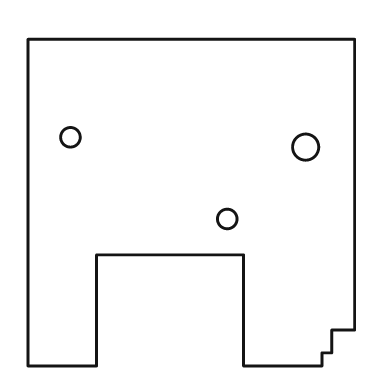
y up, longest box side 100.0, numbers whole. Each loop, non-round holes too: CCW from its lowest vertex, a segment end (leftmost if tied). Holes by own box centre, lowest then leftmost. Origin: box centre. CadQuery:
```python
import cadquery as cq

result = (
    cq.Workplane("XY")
    .moveTo(-50.0, -50.0)
    .lineTo(-29.0, -50.0)
    .lineTo(-29.0, -16.0)
    .lineTo(16.0, -16.0)
    .lineTo(16.0, -50.0)
    .lineTo(40.0, -50.0)
    .lineTo(40.0, -46.0)
    .lineTo(43.0, -46.0)
    .lineTo(43.0, -39.0)
    .lineTo(50.0, -39.0)
    .lineTo(50.0, 50.0)
    .lineTo(-50.0, 50.0)
    .close()
    .moveTo(11.0, -5.0)
    .circle(3.0)
    .moveTo(35.0, 17.0)
    .circle(4.0)
    .moveTo(-37.0, 20.0)
    .circle(3.0)
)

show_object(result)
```